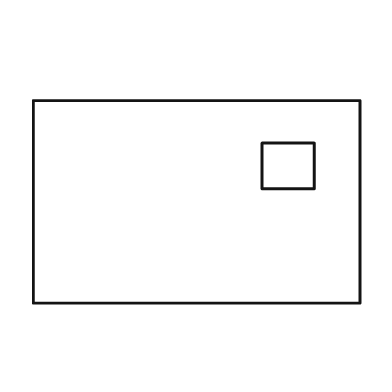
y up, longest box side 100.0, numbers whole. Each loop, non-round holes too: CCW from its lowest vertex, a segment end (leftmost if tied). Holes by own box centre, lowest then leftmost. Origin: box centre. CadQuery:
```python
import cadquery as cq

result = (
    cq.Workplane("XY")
    .moveTo(-50.0, -31.0)
    .lineTo(50.0, -31.0)
    .lineTo(50.0, 31.0)
    .lineTo(-50.0, 31.0)
    .close()
    .moveTo(20.0, 4.0)
    .lineTo(36.0, 4.0)
    .lineTo(36.0, 18.0)
    .lineTo(20.0, 18.0)
    .close()
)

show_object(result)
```